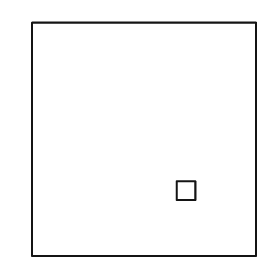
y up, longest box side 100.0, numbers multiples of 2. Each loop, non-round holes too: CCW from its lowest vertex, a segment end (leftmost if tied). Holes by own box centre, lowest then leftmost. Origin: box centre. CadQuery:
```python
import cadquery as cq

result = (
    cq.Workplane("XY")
    .moveTo(-48.0, -50.0)
    .lineTo(48.0, -50.0)
    .lineTo(48.0, 50.0)
    .lineTo(-48.0, 50.0)
    .close()
    .moveTo(14.0, -26.0)
    .lineTo(22.0, -26.0)
    .lineTo(22.0, -18.0)
    .lineTo(14.0, -18.0)
    .close()
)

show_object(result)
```